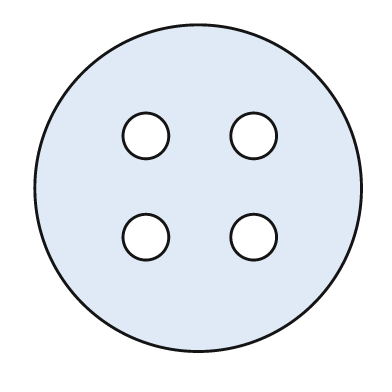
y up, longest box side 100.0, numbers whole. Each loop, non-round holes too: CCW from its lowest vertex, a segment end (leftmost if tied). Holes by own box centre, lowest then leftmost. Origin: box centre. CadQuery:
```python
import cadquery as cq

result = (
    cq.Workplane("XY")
    .moveTo(0.0, 0.0)
    .circle(50.0)
    .moveTo(-16.0, -15.0)
    .circle(7.0)
    .moveTo(17.0, -15.0)
    .circle(7.0)
    .moveTo(-16.0, 16.0)
    .circle(7.0)
    .moveTo(17.0, 16.0)
    .circle(7.0)
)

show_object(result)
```